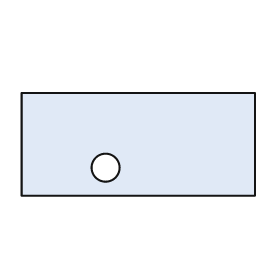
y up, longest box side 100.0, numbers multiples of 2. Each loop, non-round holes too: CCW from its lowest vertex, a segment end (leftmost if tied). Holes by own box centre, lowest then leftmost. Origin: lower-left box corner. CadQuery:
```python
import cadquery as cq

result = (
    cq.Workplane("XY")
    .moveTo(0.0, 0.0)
    .lineTo(100.0, 0.0)
    .lineTo(100.0, 44.0)
    .lineTo(0.0, 44.0)
    .close()
    .moveTo(36.0, 12.0)
    .circle(6.0)
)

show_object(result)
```